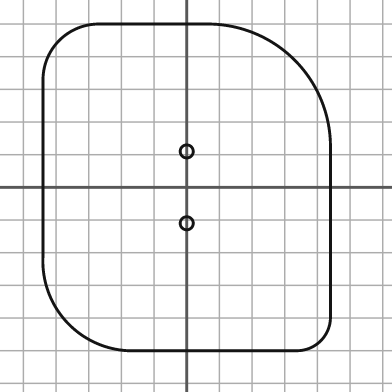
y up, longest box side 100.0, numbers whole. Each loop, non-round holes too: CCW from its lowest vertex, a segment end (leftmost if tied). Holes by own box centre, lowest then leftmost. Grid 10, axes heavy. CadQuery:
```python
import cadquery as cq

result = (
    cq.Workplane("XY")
    .moveTo(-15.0, -50.0)
    .lineTo(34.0, -50.0)
    .threePointArc((41.0, -47.0), (44.0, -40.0))
    .lineTo(44.0, 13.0)
    .threePointArc((33.0, 39.0), (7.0, 50.0))
    .lineTo(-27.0, 50.0)
    .threePointArc((-39.0, 45.0), (-44.0, 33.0))
    .lineTo(-44.0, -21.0)
    .threePointArc((-36.0, -42.0), (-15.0, -50.0))
    .close()
    .moveTo(0.0, -11.0)
    .circle(2.0)
    .moveTo(0.0, 11.0)
    .circle(2.0)
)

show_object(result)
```